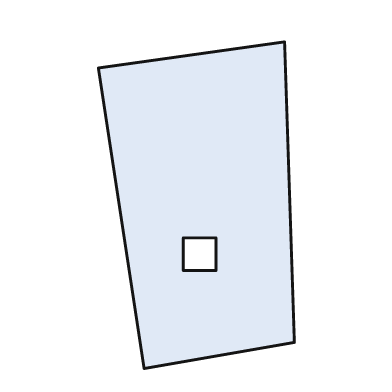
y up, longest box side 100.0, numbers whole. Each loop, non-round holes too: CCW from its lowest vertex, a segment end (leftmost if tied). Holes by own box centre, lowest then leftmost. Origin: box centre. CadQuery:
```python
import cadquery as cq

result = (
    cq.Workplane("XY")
    .moveTo(-16.0, -50.0)
    .lineTo(30.0, -42.0)
    .lineTo(27.0, 50.0)
    .lineTo(-30.0, 42.0)
    .close()
    .moveTo(-4.0, -20.0)
    .lineTo(6.0, -20.0)
    .lineTo(6.0, -10.0)
    .lineTo(-4.0, -10.0)
    .close()
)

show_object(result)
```